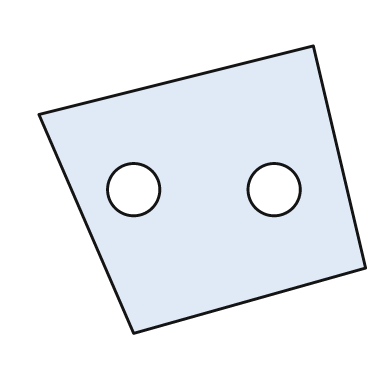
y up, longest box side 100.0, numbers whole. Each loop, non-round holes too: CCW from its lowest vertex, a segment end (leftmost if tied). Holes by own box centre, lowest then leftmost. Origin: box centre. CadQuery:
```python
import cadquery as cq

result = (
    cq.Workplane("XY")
    .moveTo(-21.0, -44.0)
    .lineTo(50.0, -24.0)
    .lineTo(34.0, 44.0)
    .lineTo(-50.0, 23.0)
    .close()
    .moveTo(-21.0, 0.0)
    .circle(8.0)
    .moveTo(22.0, 0.0)
    .circle(8.0)
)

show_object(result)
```